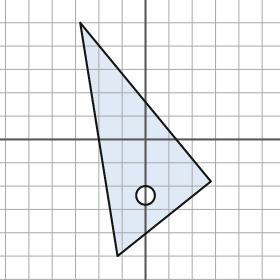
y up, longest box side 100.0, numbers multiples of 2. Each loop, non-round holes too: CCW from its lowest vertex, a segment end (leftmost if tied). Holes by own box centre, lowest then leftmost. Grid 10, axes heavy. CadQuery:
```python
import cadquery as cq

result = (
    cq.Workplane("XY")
    .moveTo(-12.0, -50.0)
    .lineTo(28.0, -18.0)
    .lineTo(-28.0, 50.0)
    .close()
    .moveTo(0.0, -24.0)
    .circle(4.0)
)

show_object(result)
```